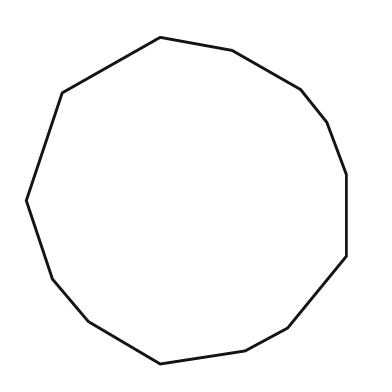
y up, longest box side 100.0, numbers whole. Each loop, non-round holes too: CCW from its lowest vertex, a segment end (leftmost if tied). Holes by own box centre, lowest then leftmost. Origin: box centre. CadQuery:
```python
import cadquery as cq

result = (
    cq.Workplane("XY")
    .moveTo(-8.0, -50.0)
    .lineTo(18.0, -46.0)
    .lineTo(31.0, -39.0)
    .lineTo(49.0, -17.0)
    .lineTo(49.0, 8.0)
    .lineTo(43.0, 24.0)
    .lineTo(35.0, 34.0)
    .lineTo(14.0, 46.0)
    .lineTo(-8.0, 50.0)
    .lineTo(-38.0, 33.0)
    .lineTo(-49.0, 0.0)
    .lineTo(-41.0, -24.0)
    .lineTo(-30.0, -37.0)
    .close()
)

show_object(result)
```